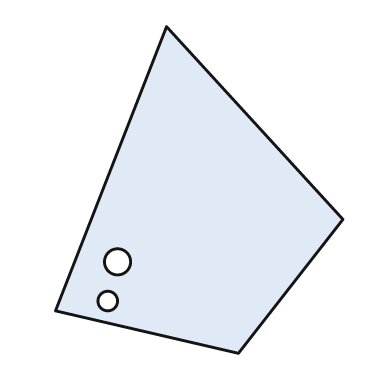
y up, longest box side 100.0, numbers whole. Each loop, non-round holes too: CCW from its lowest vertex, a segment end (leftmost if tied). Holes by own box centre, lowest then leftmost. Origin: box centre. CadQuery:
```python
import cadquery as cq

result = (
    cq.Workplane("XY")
    .moveTo(12.0, -50.0)
    .lineTo(44.0, -9.0)
    .lineTo(-10.0, 50.0)
    .lineTo(-44.0, -37.0)
    .close()
    .moveTo(-28.0, -34.0)
    .circle(3.0)
    .moveTo(-25.0, -22.0)
    .circle(4.0)
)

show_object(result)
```